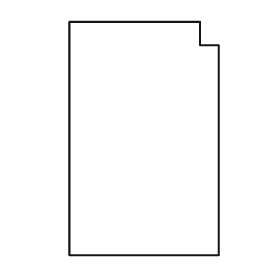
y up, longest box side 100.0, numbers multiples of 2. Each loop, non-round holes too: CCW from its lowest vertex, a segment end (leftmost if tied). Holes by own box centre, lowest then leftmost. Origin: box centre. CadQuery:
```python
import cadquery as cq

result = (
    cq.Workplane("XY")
    .moveTo(-32.0, -50.0)
    .lineTo(32.0, -50.0)
    .lineTo(32.0, 40.0)
    .lineTo(24.0, 40.0)
    .lineTo(24.0, 50.0)
    .lineTo(-32.0, 50.0)
    .close()
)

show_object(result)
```